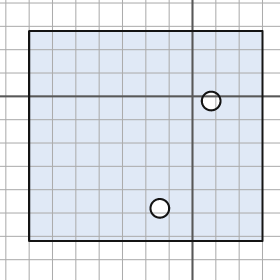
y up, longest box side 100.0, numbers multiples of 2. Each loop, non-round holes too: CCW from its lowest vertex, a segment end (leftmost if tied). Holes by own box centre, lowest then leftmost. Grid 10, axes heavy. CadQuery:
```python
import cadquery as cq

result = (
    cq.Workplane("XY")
    .moveTo(-70.0, -62.0)
    .lineTo(30.0, -62.0)
    .lineTo(30.0, 28.0)
    .lineTo(-70.0, 28.0)
    .close()
    .moveTo(-14.0, -48.0)
    .circle(4.0)
    .moveTo(8.0, -2.0)
    .circle(4.0)
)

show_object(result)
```